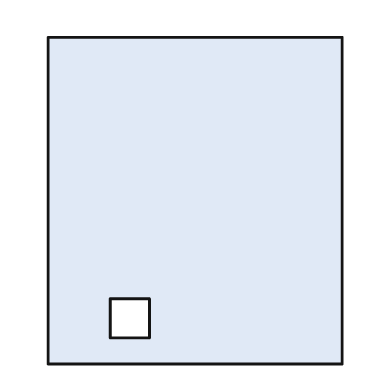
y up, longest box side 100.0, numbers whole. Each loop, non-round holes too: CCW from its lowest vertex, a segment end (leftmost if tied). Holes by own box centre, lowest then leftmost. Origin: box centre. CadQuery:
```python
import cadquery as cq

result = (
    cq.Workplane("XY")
    .moveTo(-45.0, -50.0)
    .lineTo(45.0, -50.0)
    .lineTo(45.0, 50.0)
    .lineTo(-45.0, 50.0)
    .close()
    .moveTo(-26.0, -42.0)
    .lineTo(-14.0, -42.0)
    .lineTo(-14.0, -30.0)
    .lineTo(-26.0, -30.0)
    .close()
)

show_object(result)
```